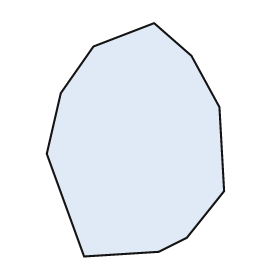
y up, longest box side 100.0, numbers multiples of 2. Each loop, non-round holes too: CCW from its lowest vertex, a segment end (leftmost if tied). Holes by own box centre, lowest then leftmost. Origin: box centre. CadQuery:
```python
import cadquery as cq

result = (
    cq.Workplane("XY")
    .moveTo(-22.0, -50.0)
    .lineTo(10.0, -48.0)
    .lineTo(22.0, -42.0)
    .lineTo(38.0, -22.0)
    .lineTo(36.0, 14.0)
    .lineTo(24.0, 36.0)
    .lineTo(8.0, 50.0)
    .lineTo(-18.0, 40.0)
    .lineTo(-32.0, 20.0)
    .lineTo(-38.0, -6.0)
    .close()
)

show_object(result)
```